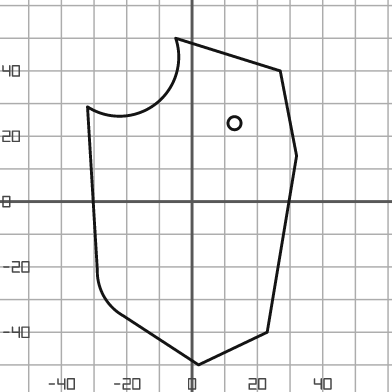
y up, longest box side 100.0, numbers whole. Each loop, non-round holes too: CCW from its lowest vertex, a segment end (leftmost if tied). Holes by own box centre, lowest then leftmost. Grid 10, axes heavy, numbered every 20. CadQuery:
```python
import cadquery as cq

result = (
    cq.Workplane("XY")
    .moveTo(2.0, -50.0)
    .lineTo(23.0, -40.0)
    .lineTo(32.0, 14.0)
    .lineTo(27.0, 40.0)
    .lineTo(-5.0, 50.0)
    .threePointArc((-11.0, 30.0), (-32.0, 29.0))
    .lineTo(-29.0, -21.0)
    .threePointArc((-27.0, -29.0), (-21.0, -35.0))
    .close()
    .moveTo(13.0, 24.0)
    .circle(2.0)
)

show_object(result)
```